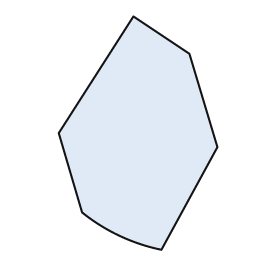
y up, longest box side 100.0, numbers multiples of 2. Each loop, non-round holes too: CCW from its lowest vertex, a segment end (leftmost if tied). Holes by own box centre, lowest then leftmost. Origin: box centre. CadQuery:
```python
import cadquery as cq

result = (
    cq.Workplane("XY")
    .moveTo(10.0, -50.0)
    .lineTo(34.0, -6.0)
    .lineTo(22.0, 34.0)
    .lineTo(-2.0, 50.0)
    .lineTo(-34.0, 0.0)
    .lineTo(-24.0, -34.0)
    .threePointArc((-8.0, -44.0), (10.0, -50.0))
    .close()
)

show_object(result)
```